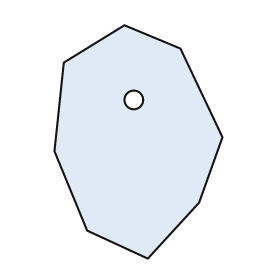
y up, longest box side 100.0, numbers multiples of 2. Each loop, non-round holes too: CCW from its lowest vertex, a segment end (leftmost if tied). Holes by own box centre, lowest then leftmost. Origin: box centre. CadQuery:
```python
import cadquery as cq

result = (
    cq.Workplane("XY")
    .moveTo(4.0, -50.0)
    .lineTo(26.0, -26.0)
    .lineTo(36.0, 2.0)
    .lineTo(18.0, 40.0)
    .lineTo(-6.0, 50.0)
    .lineTo(-32.0, 34.0)
    .lineTo(-36.0, -4.0)
    .lineTo(-22.0, -38.0)
    .close()
    .moveTo(-2.0, 18.0)
    .circle(4.0)
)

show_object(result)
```